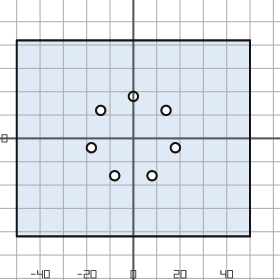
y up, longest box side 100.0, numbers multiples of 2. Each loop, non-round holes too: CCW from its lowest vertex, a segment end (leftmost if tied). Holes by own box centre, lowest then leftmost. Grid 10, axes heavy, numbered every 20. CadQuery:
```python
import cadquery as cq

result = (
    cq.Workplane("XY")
    .moveTo(-50.0, -42.0)
    .lineTo(50.0, -42.0)
    .lineTo(50.0, 42.0)
    .lineTo(-50.0, 42.0)
    .close()
    .moveTo(-8.0, -16.0)
    .circle(2.0)
    .moveTo(8.0, -16.0)
    .circle(2.0)
    .moveTo(-18.0, -4.0)
    .circle(2.0)
    .moveTo(18.0, -4.0)
    .circle(2.0)
    .moveTo(-14.0, 12.0)
    .circle(2.0)
    .moveTo(14.0, 12.0)
    .circle(2.0)
    .moveTo(0.0, 18.0)
    .circle(2.0)
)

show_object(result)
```